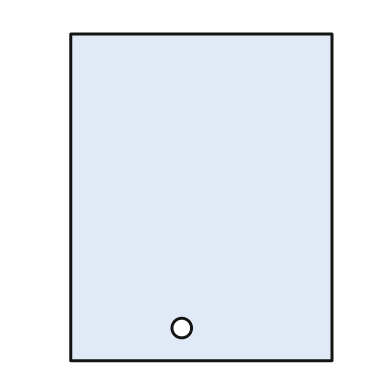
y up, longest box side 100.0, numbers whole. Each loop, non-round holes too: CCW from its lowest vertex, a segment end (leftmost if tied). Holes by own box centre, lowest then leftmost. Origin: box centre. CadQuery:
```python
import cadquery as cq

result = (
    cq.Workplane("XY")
    .moveTo(-40.0, -50.0)
    .lineTo(40.0, -50.0)
    .lineTo(40.0, 50.0)
    .lineTo(-40.0, 50.0)
    .close()
    .moveTo(-6.0, -40.0)
    .circle(3.0)
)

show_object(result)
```